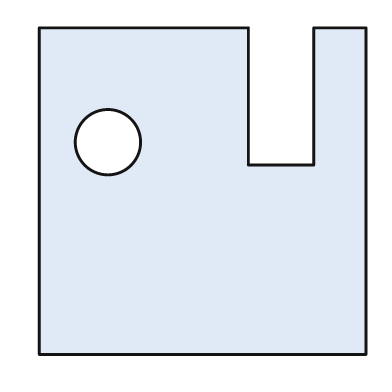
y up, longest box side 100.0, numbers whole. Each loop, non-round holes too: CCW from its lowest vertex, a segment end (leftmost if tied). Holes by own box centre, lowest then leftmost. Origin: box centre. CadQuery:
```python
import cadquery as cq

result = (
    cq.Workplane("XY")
    .moveTo(-50.0, -50.0)
    .lineTo(50.0, -50.0)
    .lineTo(50.0, 50.0)
    .lineTo(34.0, 50.0)
    .lineTo(34.0, 8.0)
    .lineTo(14.0, 8.0)
    .lineTo(14.0, 50.0)
    .lineTo(-50.0, 50.0)
    .close()
    .moveTo(-29.0, 15.0)
    .circle(10.0)
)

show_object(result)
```